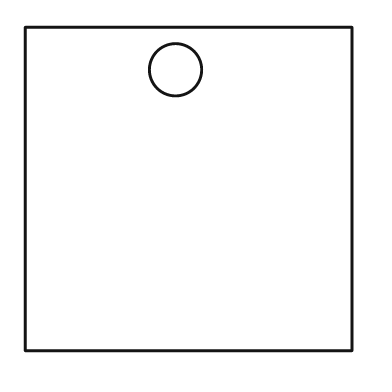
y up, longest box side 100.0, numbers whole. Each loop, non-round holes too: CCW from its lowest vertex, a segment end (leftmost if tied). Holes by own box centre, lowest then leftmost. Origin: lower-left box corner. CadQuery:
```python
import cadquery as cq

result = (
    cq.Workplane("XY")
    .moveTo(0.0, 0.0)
    .lineTo(100.0, 0.0)
    .lineTo(100.0, 99.0)
    .lineTo(0.0, 99.0)
    .close()
    .moveTo(46.0, 86.0)
    .circle(8.0)
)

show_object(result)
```